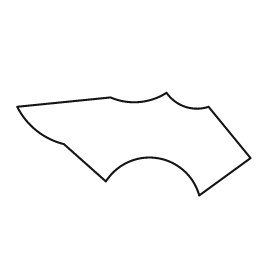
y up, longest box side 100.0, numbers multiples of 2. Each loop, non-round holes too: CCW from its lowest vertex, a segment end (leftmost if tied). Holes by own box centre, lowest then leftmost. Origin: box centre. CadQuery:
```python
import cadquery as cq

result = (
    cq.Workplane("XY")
    .moveTo(28.0, -22.0)
    .lineTo(50.0, -6.0)
    .lineTo(32.0, 16.0)
    .threePointArc((22.0, 16.0), (14.0, 22.0))
    .threePointArc((2.0, 18.0), (-10.0, 20.0))
    .lineTo(-50.0, 16.0)
    .threePointArc((-42.0, 6.0), (-30.0, 0.0))
    .lineTo(-12.0, -16.0)
    .threePointArc((10.0, -6.0), (28.0, -22.0))
    .close()
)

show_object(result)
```